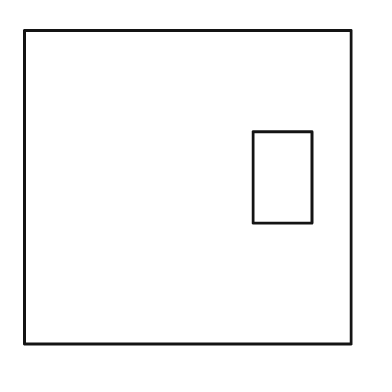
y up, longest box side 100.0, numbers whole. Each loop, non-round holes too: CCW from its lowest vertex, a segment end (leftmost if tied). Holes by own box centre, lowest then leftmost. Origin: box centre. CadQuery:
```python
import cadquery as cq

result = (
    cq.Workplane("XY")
    .moveTo(-50.0, -48.0)
    .lineTo(50.0, -48.0)
    .lineTo(50.0, 48.0)
    .lineTo(-50.0, 48.0)
    .close()
    .moveTo(20.0, -11.0)
    .lineTo(38.0, -11.0)
    .lineTo(38.0, 17.0)
    .lineTo(20.0, 17.0)
    .close()
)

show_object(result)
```